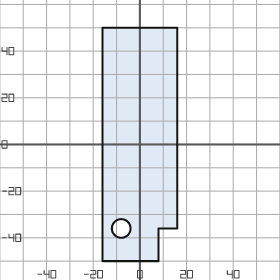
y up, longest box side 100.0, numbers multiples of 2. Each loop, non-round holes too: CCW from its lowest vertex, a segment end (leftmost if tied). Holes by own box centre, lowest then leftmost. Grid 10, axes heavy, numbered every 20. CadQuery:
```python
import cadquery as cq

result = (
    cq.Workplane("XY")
    .moveTo(-16.0, -50.0)
    .lineTo(8.0, -50.0)
    .lineTo(8.0, -36.0)
    .lineTo(16.0, -36.0)
    .lineTo(16.0, 50.0)
    .lineTo(-16.0, 50.0)
    .close()
    .moveTo(-8.0, -36.0)
    .circle(4.0)
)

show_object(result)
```